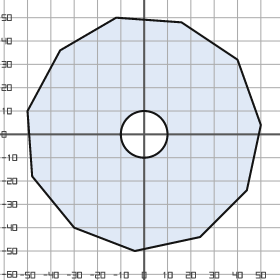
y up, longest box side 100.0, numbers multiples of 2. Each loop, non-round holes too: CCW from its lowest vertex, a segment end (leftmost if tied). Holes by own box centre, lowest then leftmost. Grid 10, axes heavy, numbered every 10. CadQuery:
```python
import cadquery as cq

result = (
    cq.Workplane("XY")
    .moveTo(-4.0, -50.0)
    .lineTo(24.0, -44.0)
    .lineTo(44.0, -24.0)
    .lineTo(50.0, 4.0)
    .lineTo(40.0, 32.0)
    .lineTo(16.0, 48.0)
    .lineTo(-12.0, 50.0)
    .lineTo(-36.0, 36.0)
    .lineTo(-50.0, 10.0)
    .lineTo(-48.0, -18.0)
    .lineTo(-30.0, -40.0)
    .close()
    .moveTo(0.0, 0.0)
    .circle(10.0)
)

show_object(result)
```